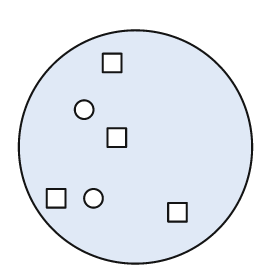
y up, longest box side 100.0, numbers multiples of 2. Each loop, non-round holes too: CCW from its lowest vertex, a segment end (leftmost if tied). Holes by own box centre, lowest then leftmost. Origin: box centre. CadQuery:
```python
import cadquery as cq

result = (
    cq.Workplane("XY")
    .moveTo(0.0, 0.0)
    .circle(50.0)
    .moveTo(14.0, -32.0)
    .lineTo(22.0, -32.0)
    .lineTo(22.0, -24.0)
    .lineTo(14.0, -24.0)
    .close()
    .moveTo(-38.0, -26.0)
    .lineTo(-30.0, -26.0)
    .lineTo(-30.0, -18.0)
    .lineTo(-38.0, -18.0)
    .close()
    .moveTo(-18.0, -22.0)
    .circle(4.0)
    .moveTo(-12.0, 0.0)
    .lineTo(-4.0, 0.0)
    .lineTo(-4.0, 8.0)
    .lineTo(-12.0, 8.0)
    .close()
    .moveTo(-22.0, 16.0)
    .circle(4.0)
    .moveTo(-14.0, 32.0)
    .lineTo(-6.0, 32.0)
    .lineTo(-6.0, 40.0)
    .lineTo(-14.0, 40.0)
    .close()
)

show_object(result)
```